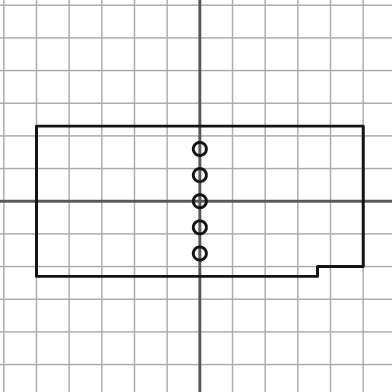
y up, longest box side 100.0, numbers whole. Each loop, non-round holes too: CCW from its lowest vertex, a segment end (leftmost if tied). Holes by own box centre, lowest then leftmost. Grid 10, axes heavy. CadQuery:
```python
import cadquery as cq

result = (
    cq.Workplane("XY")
    .moveTo(-50.0, -23.0)
    .lineTo(36.0, -23.0)
    .lineTo(36.0, -20.0)
    .lineTo(50.0, -20.0)
    .lineTo(50.0, 23.0)
    .lineTo(-50.0, 23.0)
    .close()
    .moveTo(0.0, -16.0)
    .circle(2.0)
    .moveTo(0.0, -8.0)
    .circle(2.0)
    .moveTo(0.0, 0.0)
    .circle(2.0)
    .moveTo(0.0, 8.0)
    .circle(2.0)
    .moveTo(0.0, 16.0)
    .circle(2.0)
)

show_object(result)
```